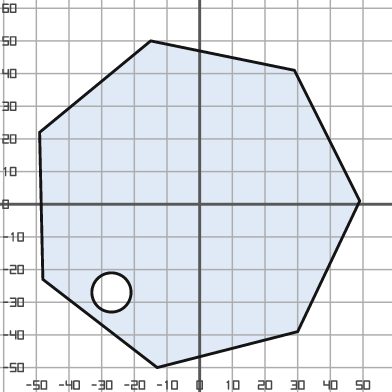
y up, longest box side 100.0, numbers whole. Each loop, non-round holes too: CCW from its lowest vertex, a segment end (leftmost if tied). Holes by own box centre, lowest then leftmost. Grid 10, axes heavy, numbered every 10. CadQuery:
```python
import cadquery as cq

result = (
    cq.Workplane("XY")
    .moveTo(-13.0, -50.0)
    .lineTo(30.0, -39.0)
    .lineTo(49.0, 1.0)
    .lineTo(29.0, 41.0)
    .lineTo(-15.0, 50.0)
    .lineTo(-49.0, 22.0)
    .lineTo(-48.0, -23.0)
    .close()
    .moveTo(-27.0, -27.0)
    .circle(6.0)
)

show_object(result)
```